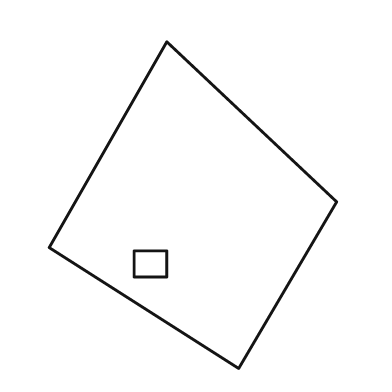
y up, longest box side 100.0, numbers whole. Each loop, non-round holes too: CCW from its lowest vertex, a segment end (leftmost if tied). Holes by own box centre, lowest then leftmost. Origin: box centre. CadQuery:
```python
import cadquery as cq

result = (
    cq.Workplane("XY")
    .moveTo(14.0, -50.0)
    .lineTo(44.0, 1.0)
    .lineTo(-8.0, 50.0)
    .lineTo(-44.0, -13.0)
    .close()
    .moveTo(-18.0, -22.0)
    .lineTo(-8.0, -22.0)
    .lineTo(-8.0, -14.0)
    .lineTo(-18.0, -14.0)
    .close()
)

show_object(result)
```